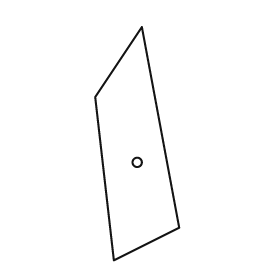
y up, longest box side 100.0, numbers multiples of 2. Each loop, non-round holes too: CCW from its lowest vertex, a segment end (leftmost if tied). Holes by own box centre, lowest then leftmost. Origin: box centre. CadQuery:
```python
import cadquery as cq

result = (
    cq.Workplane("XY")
    .moveTo(-10.0, -50.0)
    .lineTo(18.0, -36.0)
    .lineTo(2.0, 50.0)
    .lineTo(-18.0, 20.0)
    .close()
    .moveTo(0.0, -8.0)
    .circle(2.0)
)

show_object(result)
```